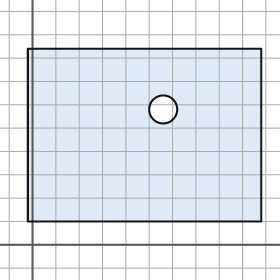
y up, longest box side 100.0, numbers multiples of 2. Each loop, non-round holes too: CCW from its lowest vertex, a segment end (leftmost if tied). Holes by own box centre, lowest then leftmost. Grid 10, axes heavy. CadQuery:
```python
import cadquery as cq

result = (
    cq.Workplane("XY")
    .moveTo(-2.0, 10.0)
    .lineTo(98.0, 10.0)
    .lineTo(98.0, 84.0)
    .lineTo(-2.0, 84.0)
    .close()
    .moveTo(56.0, 58.0)
    .circle(6.0)
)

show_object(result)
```